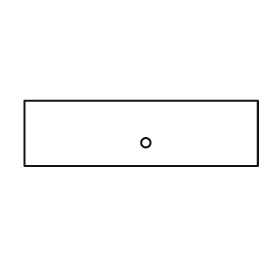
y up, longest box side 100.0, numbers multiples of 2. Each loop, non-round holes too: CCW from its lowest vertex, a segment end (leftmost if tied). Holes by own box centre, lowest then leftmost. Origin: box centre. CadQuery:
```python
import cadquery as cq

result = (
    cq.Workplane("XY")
    .moveTo(-50.0, -14.0)
    .lineTo(50.0, -14.0)
    .lineTo(50.0, 14.0)
    .lineTo(-50.0, 14.0)
    .close()
    .moveTo(2.0, -4.0)
    .circle(2.0)
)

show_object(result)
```